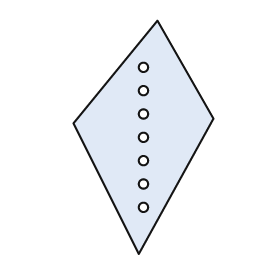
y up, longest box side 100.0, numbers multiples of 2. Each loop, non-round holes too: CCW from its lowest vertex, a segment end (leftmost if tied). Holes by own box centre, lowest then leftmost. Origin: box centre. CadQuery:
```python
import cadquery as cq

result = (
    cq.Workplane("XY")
    .moveTo(-2.0, -50.0)
    .lineTo(30.0, 8.0)
    .lineTo(6.0, 50.0)
    .lineTo(-30.0, 6.0)
    .close()
    .moveTo(0.0, -30.0)
    .circle(2.0)
    .moveTo(0.0, -20.0)
    .circle(2.0)
    .moveTo(0.0, -10.0)
    .circle(2.0)
    .moveTo(0.0, 0.0)
    .circle(2.0)
    .moveTo(0.0, 10.0)
    .circle(2.0)
    .moveTo(0.0, 20.0)
    .circle(2.0)
    .moveTo(0.0, 30.0)
    .circle(2.0)
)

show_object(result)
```